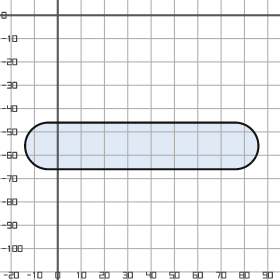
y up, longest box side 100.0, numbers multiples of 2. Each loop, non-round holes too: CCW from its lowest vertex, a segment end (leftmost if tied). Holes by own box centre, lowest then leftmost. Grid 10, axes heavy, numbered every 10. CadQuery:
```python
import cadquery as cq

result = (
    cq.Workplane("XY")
    .moveTo(-4.0, -66.0)
    .lineTo(76.0, -66.0)
    .threePointArc((86.0, -56.0), (76.0, -46.0))
    .lineTo(-4.0, -46.0)
    .threePointArc((-14.0, -56.0), (-4.0, -66.0))
    .close()
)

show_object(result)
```